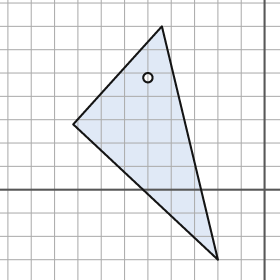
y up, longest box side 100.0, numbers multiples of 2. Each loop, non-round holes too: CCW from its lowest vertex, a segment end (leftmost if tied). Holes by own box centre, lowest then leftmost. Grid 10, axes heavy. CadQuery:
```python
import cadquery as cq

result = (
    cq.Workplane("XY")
    .moveTo(-20.0, -30.0)
    .lineTo(-44.0, 70.0)
    .lineTo(-82.0, 28.0)
    .close()
    .moveTo(-50.0, 48.0)
    .circle(2.0)
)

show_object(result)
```